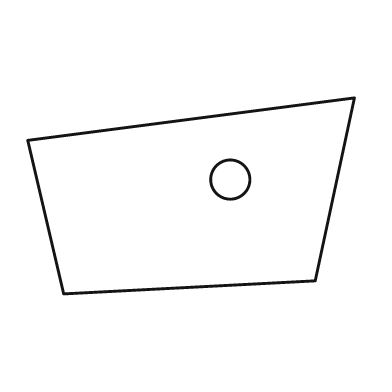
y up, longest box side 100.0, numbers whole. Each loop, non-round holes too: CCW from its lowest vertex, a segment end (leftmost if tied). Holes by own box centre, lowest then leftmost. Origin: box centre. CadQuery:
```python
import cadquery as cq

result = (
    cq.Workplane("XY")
    .moveTo(-39.0, -30.0)
    .lineTo(38.0, -26.0)
    .lineTo(50.0, 30.0)
    .lineTo(-50.0, 17.0)
    .close()
    .moveTo(12.0, 5.0)
    .circle(6.0)
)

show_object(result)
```